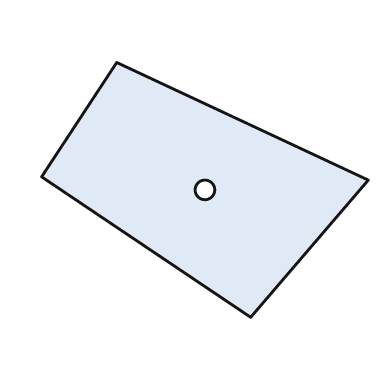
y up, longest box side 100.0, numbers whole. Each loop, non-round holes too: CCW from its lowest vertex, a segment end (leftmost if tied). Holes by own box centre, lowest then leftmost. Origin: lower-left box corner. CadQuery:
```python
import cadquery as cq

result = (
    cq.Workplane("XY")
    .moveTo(64.0, 0.0)
    .lineTo(100.0, 42.0)
    .lineTo(23.0, 78.0)
    .lineTo(0.0, 43.0)
    .close()
    .moveTo(50.0, 39.0)
    .circle(3.0)
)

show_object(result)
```